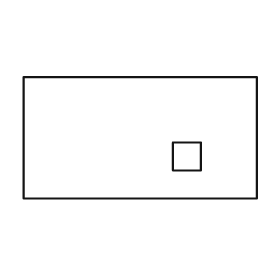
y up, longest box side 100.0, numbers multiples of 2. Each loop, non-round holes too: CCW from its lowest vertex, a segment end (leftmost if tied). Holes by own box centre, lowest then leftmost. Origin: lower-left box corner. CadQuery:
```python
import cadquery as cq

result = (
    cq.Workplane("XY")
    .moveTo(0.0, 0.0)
    .lineTo(100.0, 0.0)
    .lineTo(100.0, 52.0)
    .lineTo(0.0, 52.0)
    .close()
    .moveTo(64.0, 12.0)
    .lineTo(76.0, 12.0)
    .lineTo(76.0, 24.0)
    .lineTo(64.0, 24.0)
    .close()
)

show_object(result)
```